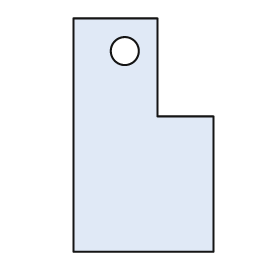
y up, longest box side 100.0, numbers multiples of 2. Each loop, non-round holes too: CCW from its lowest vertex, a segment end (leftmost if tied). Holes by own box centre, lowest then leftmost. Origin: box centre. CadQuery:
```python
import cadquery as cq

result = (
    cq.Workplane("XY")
    .moveTo(-30.0, -50.0)
    .lineTo(30.0, -50.0)
    .lineTo(30.0, 8.0)
    .lineTo(6.0, 8.0)
    .lineTo(6.0, 50.0)
    .lineTo(-30.0, 50.0)
    .close()
    .moveTo(-8.0, 36.0)
    .circle(6.0)
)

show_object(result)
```